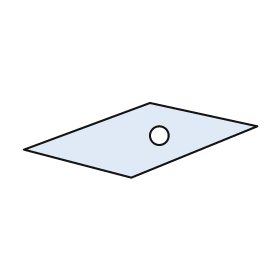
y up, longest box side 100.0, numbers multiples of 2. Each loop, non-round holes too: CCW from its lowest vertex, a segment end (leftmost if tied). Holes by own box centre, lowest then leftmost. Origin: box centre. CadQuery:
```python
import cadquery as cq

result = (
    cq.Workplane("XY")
    .moveTo(-4.0, -16.0)
    .lineTo(50.0, 6.0)
    .lineTo(4.0, 16.0)
    .lineTo(-50.0, -4.0)
    .close()
    .moveTo(8.0, 2.0)
    .circle(4.0)
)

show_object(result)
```